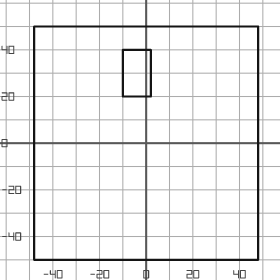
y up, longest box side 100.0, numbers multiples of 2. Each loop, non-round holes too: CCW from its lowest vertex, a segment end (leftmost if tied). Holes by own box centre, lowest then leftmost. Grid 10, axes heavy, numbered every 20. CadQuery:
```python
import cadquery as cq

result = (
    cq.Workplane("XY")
    .moveTo(-48.0, -50.0)
    .lineTo(48.0, -50.0)
    .lineTo(48.0, 50.0)
    .lineTo(-48.0, 50.0)
    .close()
    .moveTo(-10.0, 20.0)
    .lineTo(2.0, 20.0)
    .lineTo(2.0, 40.0)
    .lineTo(-10.0, 40.0)
    .close()
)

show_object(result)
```